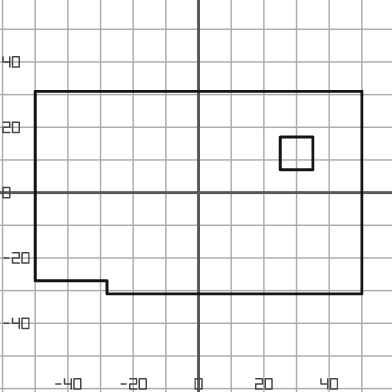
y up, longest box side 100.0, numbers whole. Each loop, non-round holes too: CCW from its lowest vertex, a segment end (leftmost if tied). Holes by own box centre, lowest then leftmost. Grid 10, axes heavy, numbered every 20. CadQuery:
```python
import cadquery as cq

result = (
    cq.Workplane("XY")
    .moveTo(-28.0, -31.0)
    .lineTo(50.0, -31.0)
    .lineTo(50.0, 31.0)
    .lineTo(-50.0, 31.0)
    .lineTo(-50.0, -27.0)
    .lineTo(-28.0, -27.0)
    .close()
    .moveTo(25.0, 7.0)
    .lineTo(35.0, 7.0)
    .lineTo(35.0, 17.0)
    .lineTo(25.0, 17.0)
    .close()
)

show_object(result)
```